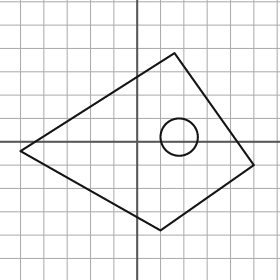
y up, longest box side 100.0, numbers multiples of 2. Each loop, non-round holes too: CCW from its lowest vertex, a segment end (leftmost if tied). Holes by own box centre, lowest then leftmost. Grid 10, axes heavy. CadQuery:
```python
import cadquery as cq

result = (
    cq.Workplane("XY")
    .moveTo(10.0, -38.0)
    .lineTo(50.0, -10.0)
    .lineTo(16.0, 38.0)
    .lineTo(-50.0, -4.0)
    .close()
    .moveTo(18.0, 2.0)
    .circle(8.0)
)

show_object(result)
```